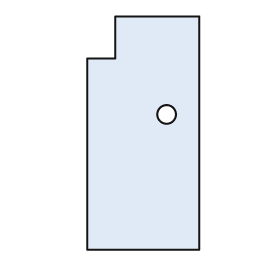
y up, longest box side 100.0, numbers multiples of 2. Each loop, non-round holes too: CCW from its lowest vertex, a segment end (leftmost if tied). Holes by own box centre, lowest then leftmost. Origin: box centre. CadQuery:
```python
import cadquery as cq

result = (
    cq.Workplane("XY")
    .moveTo(-24.0, -50.0)
    .lineTo(24.0, -50.0)
    .lineTo(24.0, 50.0)
    .lineTo(-12.0, 50.0)
    .lineTo(-12.0, 32.0)
    .lineTo(-24.0, 32.0)
    .close()
    .moveTo(10.0, 8.0)
    .circle(4.0)
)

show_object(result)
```